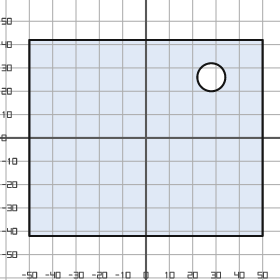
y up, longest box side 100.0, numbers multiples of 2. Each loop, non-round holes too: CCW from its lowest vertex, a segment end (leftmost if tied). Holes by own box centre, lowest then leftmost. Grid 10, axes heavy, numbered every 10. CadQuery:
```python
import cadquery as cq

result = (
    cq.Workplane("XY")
    .moveTo(-50.0, -42.0)
    .lineTo(50.0, -42.0)
    .lineTo(50.0, 42.0)
    .lineTo(-50.0, 42.0)
    .close()
    .moveTo(28.0, 26.0)
    .circle(6.0)
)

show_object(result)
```